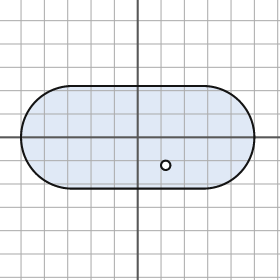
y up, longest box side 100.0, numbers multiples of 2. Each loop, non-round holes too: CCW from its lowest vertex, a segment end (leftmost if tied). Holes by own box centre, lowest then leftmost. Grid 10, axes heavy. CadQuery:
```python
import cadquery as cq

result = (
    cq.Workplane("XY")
    .moveTo(-28.0, -22.0)
    .lineTo(28.0, -22.0)
    .threePointArc((50.0, 0.0), (28.0, 22.0))
    .lineTo(-28.0, 22.0)
    .threePointArc((-50.0, 0.0), (-28.0, -22.0))
    .close()
    .moveTo(12.0, -12.0)
    .circle(2.0)
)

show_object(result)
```